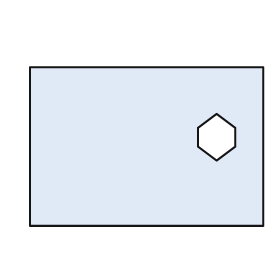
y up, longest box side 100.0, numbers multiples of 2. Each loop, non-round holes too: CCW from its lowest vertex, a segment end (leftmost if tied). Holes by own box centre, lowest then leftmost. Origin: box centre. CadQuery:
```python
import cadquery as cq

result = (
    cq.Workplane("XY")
    .moveTo(-50.0, -34.0)
    .lineTo(50.0, -34.0)
    .lineTo(50.0, 34.0)
    .lineTo(-50.0, 34.0)
    .close()
    .moveTo(30.0, -6.0)
    .lineTo(38.0, 0.0)
    .lineTo(38.0, 8.0)
    .lineTo(30.0, 14.0)
    .lineTo(22.0, 8.0)
    .lineTo(22.0, 0.0)
    .close()
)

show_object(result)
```